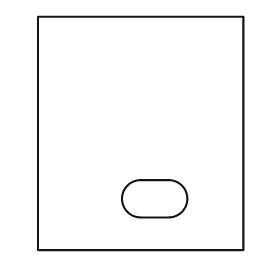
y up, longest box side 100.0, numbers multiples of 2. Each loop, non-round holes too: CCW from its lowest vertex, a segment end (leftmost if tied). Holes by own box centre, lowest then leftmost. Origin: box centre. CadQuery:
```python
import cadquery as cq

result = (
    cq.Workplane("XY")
    .moveTo(-44.0, -50.0)
    .lineTo(44.0, -50.0)
    .lineTo(44.0, 50.0)
    .lineTo(-44.0, 50.0)
    .close()
    .moveTo(0.0, -36.0)
    .lineTo(12.0, -36.0)
    .threePointArc((20.0, -28.0), (12.0, -20.0))
    .lineTo(0.0, -20.0)
    .threePointArc((-8.0, -28.0), (0.0, -36.0))
    .close()
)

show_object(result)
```